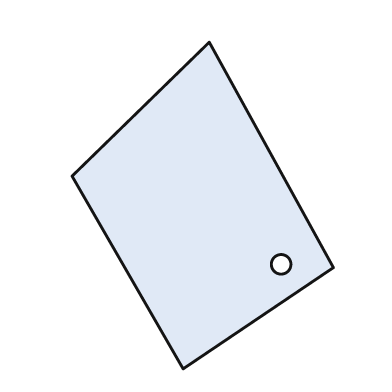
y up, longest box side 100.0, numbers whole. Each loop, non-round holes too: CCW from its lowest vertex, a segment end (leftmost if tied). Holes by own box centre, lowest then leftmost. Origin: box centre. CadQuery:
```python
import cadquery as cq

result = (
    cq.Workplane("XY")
    .moveTo(-6.0, -50.0)
    .lineTo(40.0, -19.0)
    .lineTo(2.0, 50.0)
    .lineTo(-40.0, 9.0)
    .close()
    .moveTo(24.0, -18.0)
    .circle(3.0)
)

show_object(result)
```